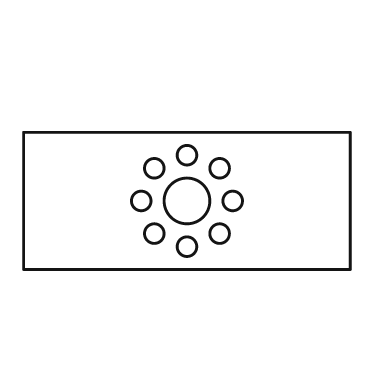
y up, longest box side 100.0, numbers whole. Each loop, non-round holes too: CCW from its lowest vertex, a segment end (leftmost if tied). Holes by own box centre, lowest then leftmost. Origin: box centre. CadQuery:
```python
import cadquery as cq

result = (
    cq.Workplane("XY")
    .moveTo(-50.0, -21.0)
    .lineTo(50.0, -21.0)
    .lineTo(50.0, 21.0)
    .lineTo(-50.0, 21.0)
    .close()
    .moveTo(0.0, -14.0)
    .circle(3.0)
    .moveTo(-10.0, -10.0)
    .circle(3.0)
    .moveTo(10.0, -10.0)
    .circle(3.0)
    .moveTo(-14.0, 0.0)
    .circle(3.0)
    .moveTo(0.0, 0.0)
    .circle(7.0)
    .moveTo(14.0, 0.0)
    .circle(3.0)
    .moveTo(-10.0, 10.0)
    .circle(3.0)
    .moveTo(10.0, 10.0)
    .circle(3.0)
    .moveTo(0.0, 14.0)
    .circle(3.0)
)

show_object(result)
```